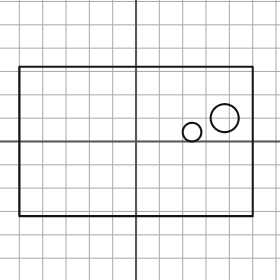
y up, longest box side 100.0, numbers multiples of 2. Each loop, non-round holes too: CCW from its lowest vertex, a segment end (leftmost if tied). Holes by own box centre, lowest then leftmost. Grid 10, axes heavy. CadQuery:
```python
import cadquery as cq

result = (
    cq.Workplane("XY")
    .moveTo(-50.0, -32.0)
    .lineTo(50.0, -32.0)
    .lineTo(50.0, 32.0)
    .lineTo(-50.0, 32.0)
    .close()
    .moveTo(24.0, 4.0)
    .circle(4.0)
    .moveTo(38.0, 10.0)
    .circle(6.0)
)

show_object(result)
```